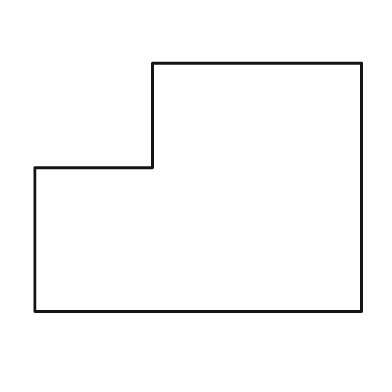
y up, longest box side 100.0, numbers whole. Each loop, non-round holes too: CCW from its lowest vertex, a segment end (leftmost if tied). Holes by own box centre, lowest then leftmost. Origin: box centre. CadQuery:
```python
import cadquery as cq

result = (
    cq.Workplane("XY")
    .moveTo(-50.0, -38.0)
    .lineTo(50.0, -38.0)
    .lineTo(50.0, 38.0)
    .lineTo(-14.0, 38.0)
    .lineTo(-14.0, 6.0)
    .lineTo(-50.0, 6.0)
    .close()
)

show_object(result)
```